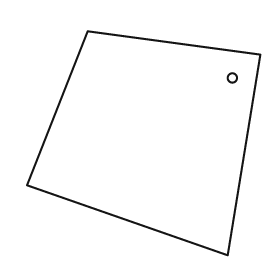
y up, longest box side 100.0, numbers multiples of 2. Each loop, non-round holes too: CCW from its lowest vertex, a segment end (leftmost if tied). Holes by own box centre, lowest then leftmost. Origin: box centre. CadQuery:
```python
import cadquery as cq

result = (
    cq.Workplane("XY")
    .moveTo(36.0, -48.0)
    .lineTo(50.0, 38.0)
    .lineTo(-24.0, 48.0)
    .lineTo(-50.0, -18.0)
    .close()
    .moveTo(38.0, 28.0)
    .circle(2.0)
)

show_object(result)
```